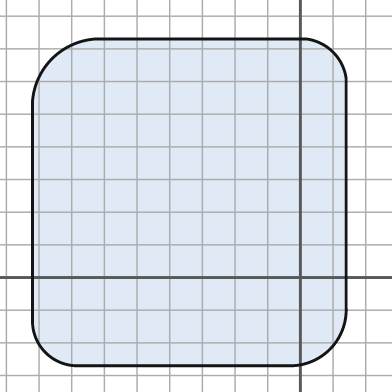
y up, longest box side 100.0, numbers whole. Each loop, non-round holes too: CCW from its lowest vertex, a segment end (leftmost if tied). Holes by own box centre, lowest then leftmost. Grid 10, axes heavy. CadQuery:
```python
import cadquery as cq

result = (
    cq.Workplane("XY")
    .moveTo(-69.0, -27.0)
    .lineTo(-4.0, -27.0)
    .threePointArc((9.0, -22.0), (14.0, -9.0))
    .lineTo(14.0, 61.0)
    .threePointArc((10.0, 69.0), (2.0, 73.0))
    .lineTo(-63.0, 73.0)
    .threePointArc((-76.0, 67.0), (-82.0, 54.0))
    .lineTo(-82.0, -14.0)
    .threePointArc((-78.0, -23.0), (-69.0, -27.0))
    .close()
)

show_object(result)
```